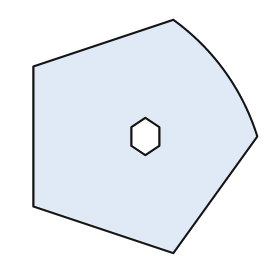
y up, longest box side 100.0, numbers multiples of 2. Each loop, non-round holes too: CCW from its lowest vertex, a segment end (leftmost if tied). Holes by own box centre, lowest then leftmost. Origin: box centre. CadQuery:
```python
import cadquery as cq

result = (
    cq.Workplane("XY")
    .moveTo(12.0, -50.0)
    .lineTo(48.0, 0.0)
    .threePointArc((34.0, 28.0), (12.0, 50.0))
    .lineTo(-48.0, 30.0)
    .lineTo(-48.0, -30.0)
    .close()
    .moveTo(0.0, -8.0)
    .lineTo(6.0, -4.0)
    .lineTo(6.0, 4.0)
    .lineTo(0.0, 8.0)
    .lineTo(-6.0, 4.0)
    .lineTo(-6.0, -4.0)
    .close()
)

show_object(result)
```